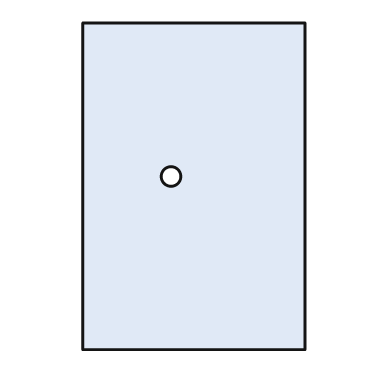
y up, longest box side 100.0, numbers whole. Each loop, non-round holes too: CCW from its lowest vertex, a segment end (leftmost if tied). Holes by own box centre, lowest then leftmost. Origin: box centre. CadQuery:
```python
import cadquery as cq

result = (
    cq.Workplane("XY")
    .moveTo(-34.0, -50.0)
    .lineTo(34.0, -50.0)
    .lineTo(34.0, 50.0)
    .lineTo(-34.0, 50.0)
    .close()
    .moveTo(-7.0, 3.0)
    .circle(3.0)
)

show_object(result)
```